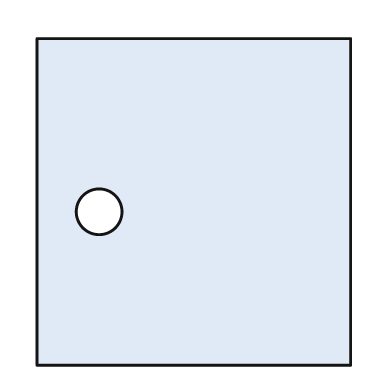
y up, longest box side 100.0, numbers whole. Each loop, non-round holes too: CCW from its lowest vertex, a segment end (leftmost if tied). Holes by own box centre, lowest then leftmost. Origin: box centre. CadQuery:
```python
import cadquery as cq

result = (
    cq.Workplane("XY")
    .moveTo(-48.0, -50.0)
    .lineTo(48.0, -50.0)
    .lineTo(48.0, 50.0)
    .lineTo(-48.0, 50.0)
    .close()
    .moveTo(-29.0, -3.0)
    .circle(7.0)
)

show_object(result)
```